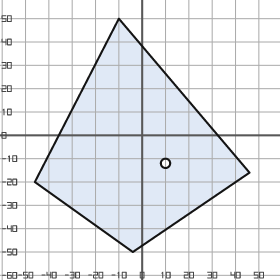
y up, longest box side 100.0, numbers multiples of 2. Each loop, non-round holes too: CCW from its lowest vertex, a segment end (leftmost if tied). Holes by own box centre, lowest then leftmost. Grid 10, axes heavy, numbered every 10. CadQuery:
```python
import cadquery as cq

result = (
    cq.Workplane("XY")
    .moveTo(-4.0, -50.0)
    .lineTo(46.0, -16.0)
    .lineTo(-10.0, 50.0)
    .lineTo(-46.0, -20.0)
    .close()
    .moveTo(10.0, -12.0)
    .circle(2.0)
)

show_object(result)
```